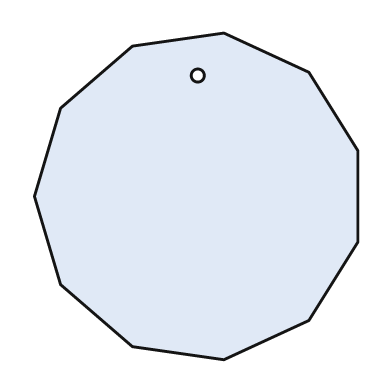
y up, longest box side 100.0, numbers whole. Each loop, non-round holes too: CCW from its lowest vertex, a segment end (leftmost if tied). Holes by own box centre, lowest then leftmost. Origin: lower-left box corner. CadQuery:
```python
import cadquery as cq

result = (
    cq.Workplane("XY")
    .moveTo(58.0, 0.0)
    .lineTo(84.0, 12.0)
    .lineTo(99.0, 36.0)
    .lineTo(99.0, 64.0)
    .lineTo(84.0, 88.0)
    .lineTo(58.0, 100.0)
    .lineTo(30.0, 96.0)
    .lineTo(8.0, 77.0)
    .lineTo(0.0, 50.0)
    .lineTo(8.0, 23.0)
    .lineTo(30.0, 4.0)
    .close()
    .moveTo(50.0, 87.0)
    .circle(2.0)
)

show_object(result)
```